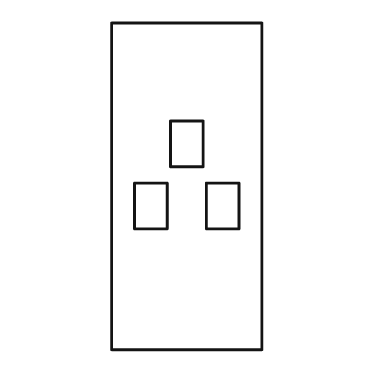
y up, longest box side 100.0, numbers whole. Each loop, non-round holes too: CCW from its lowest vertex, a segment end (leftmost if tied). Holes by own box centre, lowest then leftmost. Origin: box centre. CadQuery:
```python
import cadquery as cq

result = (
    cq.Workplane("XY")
    .moveTo(-23.0, -50.0)
    .lineTo(23.0, -50.0)
    .lineTo(23.0, 50.0)
    .lineTo(-23.0, 50.0)
    .close()
    .moveTo(-16.0, -13.0)
    .lineTo(-6.0, -13.0)
    .lineTo(-6.0, 1.0)
    .lineTo(-16.0, 1.0)
    .close()
    .moveTo(6.0, -13.0)
    .lineTo(16.0, -13.0)
    .lineTo(16.0, 1.0)
    .lineTo(6.0, 1.0)
    .close()
    .moveTo(-5.0, 6.0)
    .lineTo(5.0, 6.0)
    .lineTo(5.0, 20.0)
    .lineTo(-5.0, 20.0)
    .close()
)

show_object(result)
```